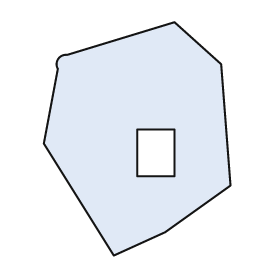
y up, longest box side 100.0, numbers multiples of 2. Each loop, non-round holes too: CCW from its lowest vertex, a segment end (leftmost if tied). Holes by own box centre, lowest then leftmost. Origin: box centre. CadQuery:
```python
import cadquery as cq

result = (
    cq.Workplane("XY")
    .moveTo(-10.0, -50.0)
    .lineTo(12.0, -40.0)
    .lineTo(40.0, -20.0)
    .lineTo(36.0, 32.0)
    .lineTo(16.0, 50.0)
    .lineTo(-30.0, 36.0)
    .threePointArc((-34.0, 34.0), (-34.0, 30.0))
    .lineTo(-40.0, -2.0)
    .close()
    .moveTo(0.0, -16.0)
    .lineTo(16.0, -16.0)
    .lineTo(16.0, 4.0)
    .lineTo(0.0, 4.0)
    .close()
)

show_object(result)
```